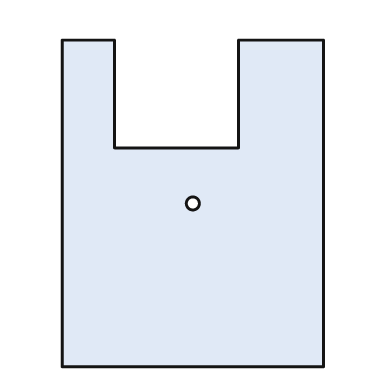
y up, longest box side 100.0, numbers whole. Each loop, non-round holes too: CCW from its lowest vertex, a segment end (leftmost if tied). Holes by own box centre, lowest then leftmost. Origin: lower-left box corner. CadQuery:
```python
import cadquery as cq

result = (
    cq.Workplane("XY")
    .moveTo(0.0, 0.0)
    .lineTo(80.0, 0.0)
    .lineTo(80.0, 100.0)
    .lineTo(54.0, 100.0)
    .lineTo(54.0, 67.0)
    .lineTo(16.0, 67.0)
    .lineTo(16.0, 100.0)
    .lineTo(0.0, 100.0)
    .close()
    .moveTo(40.0, 50.0)
    .circle(2.0)
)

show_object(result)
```